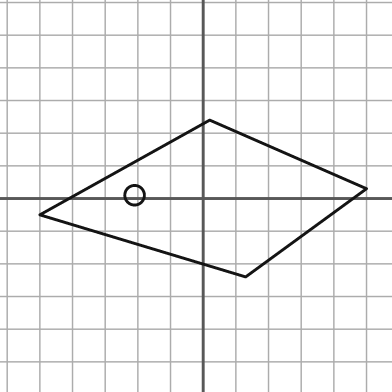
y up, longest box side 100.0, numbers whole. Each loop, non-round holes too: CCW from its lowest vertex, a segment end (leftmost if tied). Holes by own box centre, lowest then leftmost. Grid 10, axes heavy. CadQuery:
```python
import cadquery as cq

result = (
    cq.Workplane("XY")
    .moveTo(13.0, -24.0)
    .lineTo(50.0, 3.0)
    .lineTo(2.0, 24.0)
    .lineTo(-50.0, -5.0)
    .close()
    .moveTo(-21.0, 1.0)
    .circle(3.0)
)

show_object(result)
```